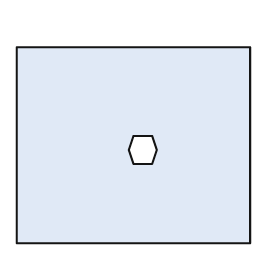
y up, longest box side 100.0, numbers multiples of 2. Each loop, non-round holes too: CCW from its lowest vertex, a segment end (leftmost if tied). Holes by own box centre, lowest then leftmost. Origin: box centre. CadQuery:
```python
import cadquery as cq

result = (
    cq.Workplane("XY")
    .moveTo(-50.0, -42.0)
    .lineTo(50.0, -42.0)
    .lineTo(50.0, 42.0)
    .lineTo(-50.0, 42.0)
    .close()
    .moveTo(0.0, -8.0)
    .lineTo(8.0, -8.0)
    .lineTo(10.0, -2.0)
    .lineTo(8.0, 4.0)
    .lineTo(0.0, 4.0)
    .lineTo(-2.0, -2.0)
    .close()
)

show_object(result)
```